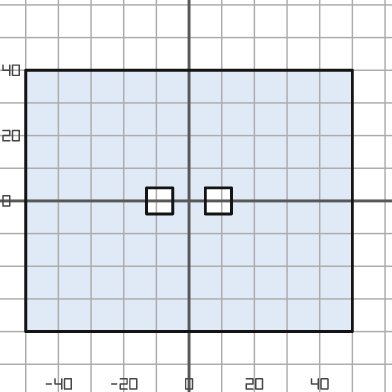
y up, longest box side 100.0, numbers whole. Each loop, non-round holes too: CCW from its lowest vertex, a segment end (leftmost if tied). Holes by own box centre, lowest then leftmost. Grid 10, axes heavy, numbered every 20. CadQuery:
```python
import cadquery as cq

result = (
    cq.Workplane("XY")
    .moveTo(-50.0, -40.0)
    .lineTo(50.0, -40.0)
    .lineTo(50.0, 40.0)
    .lineTo(-50.0, 40.0)
    .close()
    .moveTo(-13.0, -4.0)
    .lineTo(-5.0, -4.0)
    .lineTo(-5.0, 4.0)
    .lineTo(-13.0, 4.0)
    .close()
    .moveTo(5.0, -4.0)
    .lineTo(13.0, -4.0)
    .lineTo(13.0, 4.0)
    .lineTo(5.0, 4.0)
    .close()
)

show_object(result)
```